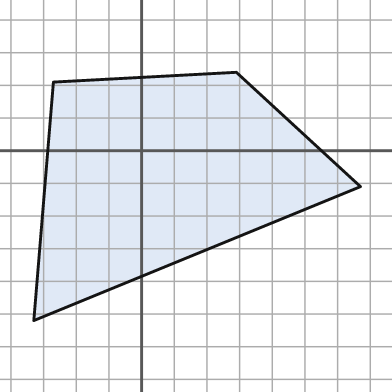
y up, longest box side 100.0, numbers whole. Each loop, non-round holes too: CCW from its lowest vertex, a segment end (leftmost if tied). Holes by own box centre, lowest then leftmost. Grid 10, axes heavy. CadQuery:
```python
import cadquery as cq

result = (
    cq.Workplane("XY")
    .moveTo(-33.0, -52.0)
    .lineTo(67.0, -11.0)
    .lineTo(29.0, 24.0)
    .lineTo(-27.0, 21.0)
    .close()
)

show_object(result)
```